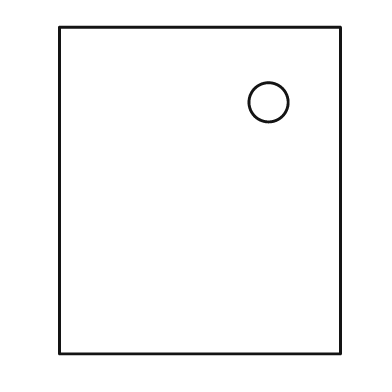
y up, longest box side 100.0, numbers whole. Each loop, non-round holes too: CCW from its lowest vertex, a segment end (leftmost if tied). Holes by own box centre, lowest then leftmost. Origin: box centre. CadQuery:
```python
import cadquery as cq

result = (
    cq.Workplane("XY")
    .moveTo(-43.0, -50.0)
    .lineTo(43.0, -50.0)
    .lineTo(43.0, 50.0)
    .lineTo(-43.0, 50.0)
    .close()
    .moveTo(21.0, 27.0)
    .circle(6.0)
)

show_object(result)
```